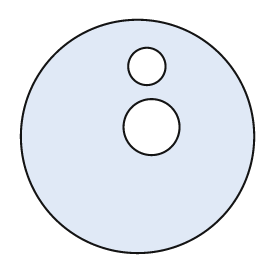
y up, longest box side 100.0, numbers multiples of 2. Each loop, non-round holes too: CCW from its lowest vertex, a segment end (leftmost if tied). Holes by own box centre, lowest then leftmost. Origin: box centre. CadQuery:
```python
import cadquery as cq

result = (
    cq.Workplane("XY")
    .moveTo(0.0, 0.0)
    .circle(50.0)
    .moveTo(6.0, 4.0)
    .circle(12.0)
    .moveTo(4.0, 30.0)
    .circle(8.0)
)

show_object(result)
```